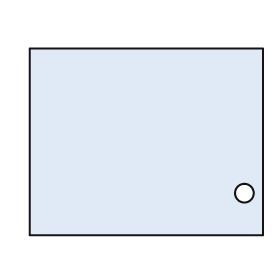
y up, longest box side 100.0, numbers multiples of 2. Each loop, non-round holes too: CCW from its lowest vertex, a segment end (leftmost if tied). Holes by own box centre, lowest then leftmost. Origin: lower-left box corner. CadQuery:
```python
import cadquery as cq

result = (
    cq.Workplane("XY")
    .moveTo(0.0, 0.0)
    .lineTo(100.0, 0.0)
    .lineTo(100.0, 80.0)
    .lineTo(0.0, 80.0)
    .close()
    .moveTo(92.0, 18.0)
    .circle(4.0)
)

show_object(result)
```